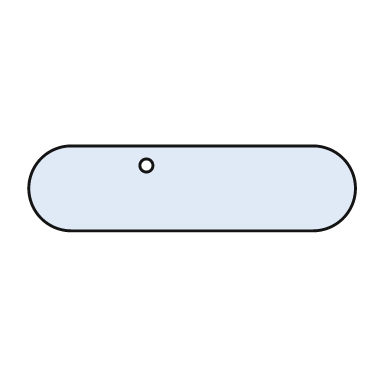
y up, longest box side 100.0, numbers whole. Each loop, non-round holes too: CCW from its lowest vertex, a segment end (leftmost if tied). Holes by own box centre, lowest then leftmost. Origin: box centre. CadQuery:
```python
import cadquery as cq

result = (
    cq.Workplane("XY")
    .moveTo(-37.0, -13.0)
    .lineTo(37.0, -13.0)
    .threePointArc((50.0, 0.0), (37.0, 13.0))
    .lineTo(-37.0, 13.0)
    .threePointArc((-50.0, 0.0), (-37.0, -13.0))
    .close()
    .moveTo(-14.0, 7.0)
    .circle(2.0)
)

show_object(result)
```